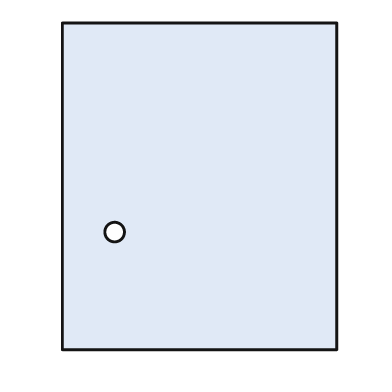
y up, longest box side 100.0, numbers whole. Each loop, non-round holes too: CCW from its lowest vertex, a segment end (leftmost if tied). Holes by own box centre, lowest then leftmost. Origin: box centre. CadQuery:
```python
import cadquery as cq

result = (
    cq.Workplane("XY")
    .moveTo(-42.0, -50.0)
    .lineTo(42.0, -50.0)
    .lineTo(42.0, 50.0)
    .lineTo(-42.0, 50.0)
    .close()
    .moveTo(-26.0, -14.0)
    .circle(3.0)
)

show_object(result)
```